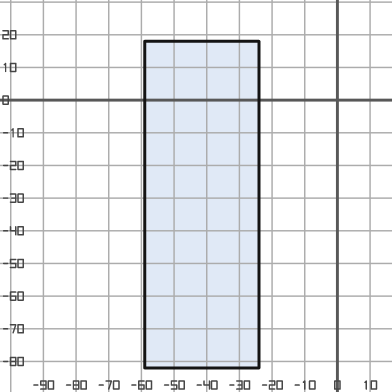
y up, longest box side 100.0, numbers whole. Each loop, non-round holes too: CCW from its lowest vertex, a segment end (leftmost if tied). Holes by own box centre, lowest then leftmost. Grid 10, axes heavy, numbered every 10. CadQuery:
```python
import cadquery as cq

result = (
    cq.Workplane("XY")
    .moveTo(-59.0, -82.0)
    .lineTo(-24.0, -82.0)
    .lineTo(-24.0, 18.0)
    .lineTo(-59.0, 18.0)
    .close()
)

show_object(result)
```